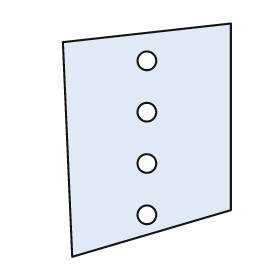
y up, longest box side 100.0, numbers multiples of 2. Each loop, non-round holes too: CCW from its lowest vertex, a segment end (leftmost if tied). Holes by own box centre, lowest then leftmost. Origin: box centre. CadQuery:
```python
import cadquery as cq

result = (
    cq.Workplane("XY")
    .moveTo(-32.0, -50.0)
    .lineTo(36.0, -30.0)
    .lineTo(36.0, 50.0)
    .lineTo(-36.0, 42.0)
    .close()
    .moveTo(0.0, -32.0)
    .circle(4.0)
    .moveTo(0.0, -10.0)
    .circle(4.0)
    .moveTo(0.0, 12.0)
    .circle(4.0)
    .moveTo(0.0, 34.0)
    .circle(4.0)
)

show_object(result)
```